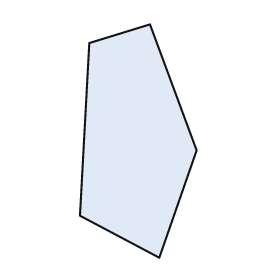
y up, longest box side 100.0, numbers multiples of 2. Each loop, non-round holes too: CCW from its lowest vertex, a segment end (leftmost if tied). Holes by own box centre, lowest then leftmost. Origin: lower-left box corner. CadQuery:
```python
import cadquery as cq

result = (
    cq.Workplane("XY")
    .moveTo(34.0, 0.0)
    .lineTo(50.0, 46.0)
    .lineTo(30.0, 100.0)
    .lineTo(4.0, 92.0)
    .lineTo(0.0, 18.0)
    .close()
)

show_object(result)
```